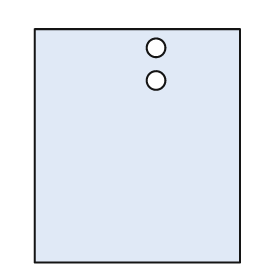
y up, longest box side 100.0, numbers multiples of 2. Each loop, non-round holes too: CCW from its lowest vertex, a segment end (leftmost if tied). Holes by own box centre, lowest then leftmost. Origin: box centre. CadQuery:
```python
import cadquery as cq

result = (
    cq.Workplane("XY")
    .moveTo(-44.0, -50.0)
    .lineTo(44.0, -50.0)
    .lineTo(44.0, 50.0)
    .lineTo(-44.0, 50.0)
    .close()
    .moveTo(8.0, 28.0)
    .circle(4.0)
    .moveTo(8.0, 42.0)
    .circle(4.0)
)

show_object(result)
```